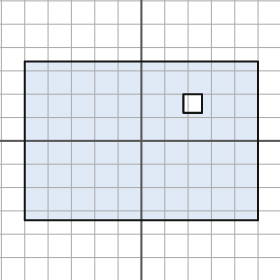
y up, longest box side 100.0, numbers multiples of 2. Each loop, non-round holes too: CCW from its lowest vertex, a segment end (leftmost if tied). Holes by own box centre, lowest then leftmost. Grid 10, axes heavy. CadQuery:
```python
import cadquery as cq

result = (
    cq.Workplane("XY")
    .moveTo(-50.0, -34.0)
    .lineTo(50.0, -34.0)
    .lineTo(50.0, 34.0)
    .lineTo(-50.0, 34.0)
    .close()
    .moveTo(18.0, 12.0)
    .lineTo(26.0, 12.0)
    .lineTo(26.0, 20.0)
    .lineTo(18.0, 20.0)
    .close()
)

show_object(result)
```